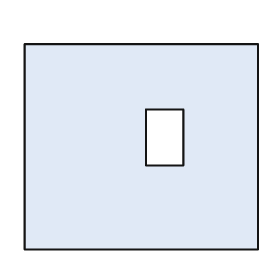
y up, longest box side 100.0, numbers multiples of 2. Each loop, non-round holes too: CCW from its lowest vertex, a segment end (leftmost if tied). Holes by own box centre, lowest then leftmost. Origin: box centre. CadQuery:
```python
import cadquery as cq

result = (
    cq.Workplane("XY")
    .moveTo(-50.0, -44.0)
    .lineTo(50.0, -44.0)
    .lineTo(50.0, 44.0)
    .lineTo(-50.0, 44.0)
    .close()
    .moveTo(2.0, -8.0)
    .lineTo(18.0, -8.0)
    .lineTo(18.0, 16.0)
    .lineTo(2.0, 16.0)
    .close()
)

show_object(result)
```